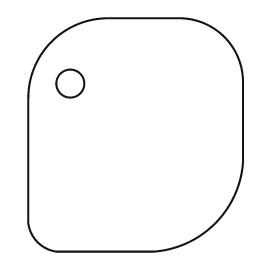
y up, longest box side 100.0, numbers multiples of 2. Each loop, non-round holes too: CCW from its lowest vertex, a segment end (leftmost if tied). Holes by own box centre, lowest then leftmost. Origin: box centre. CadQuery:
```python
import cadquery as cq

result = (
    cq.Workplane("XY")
    .moveTo(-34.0, -50.0)
    .lineTo(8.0, -50.0)
    .threePointArc((34.0, -38.0), (46.0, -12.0))
    .lineTo(46.0, 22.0)
    .threePointArc((38.0, 42.0), (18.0, 50.0))
    .lineTo(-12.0, 50.0)
    .threePointArc((-36.0, 40.0), (-46.0, 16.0))
    .lineTo(-46.0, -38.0)
    .threePointArc((-42.0, -46.0), (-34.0, -50.0))
    .close()
    .moveTo(-28.0, 22.0)
    .circle(6.0)
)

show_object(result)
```